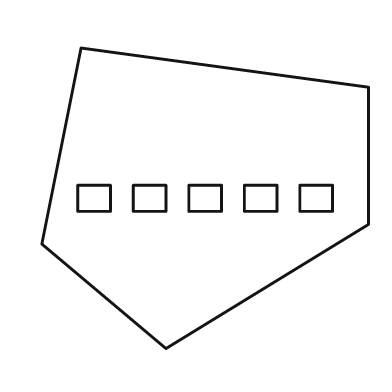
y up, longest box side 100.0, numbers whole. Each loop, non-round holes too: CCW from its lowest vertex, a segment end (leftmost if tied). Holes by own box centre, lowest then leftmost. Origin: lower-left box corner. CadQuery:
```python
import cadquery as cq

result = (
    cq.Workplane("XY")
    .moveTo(38.0, 0.0)
    .lineTo(100.0, 38.0)
    .lineTo(100.0, 80.0)
    .lineTo(12.0, 92.0)
    .lineTo(0.0, 32.0)
    .close()
    .moveTo(11.0, 42.0)
    .lineTo(21.0, 42.0)
    .lineTo(21.0, 50.0)
    .lineTo(11.0, 50.0)
    .close()
    .moveTo(28.0, 42.0)
    .lineTo(38.0, 42.0)
    .lineTo(38.0, 50.0)
    .lineTo(28.0, 50.0)
    .close()
    .moveTo(45.0, 42.0)
    .lineTo(55.0, 42.0)
    .lineTo(55.0, 50.0)
    .lineTo(45.0, 50.0)
    .close()
    .moveTo(62.0, 42.0)
    .lineTo(72.0, 42.0)
    .lineTo(72.0, 50.0)
    .lineTo(62.0, 50.0)
    .close()
    .moveTo(79.0, 42.0)
    .lineTo(89.0, 42.0)
    .lineTo(89.0, 50.0)
    .lineTo(79.0, 50.0)
    .close()
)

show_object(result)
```